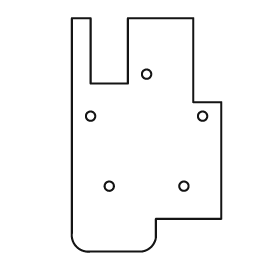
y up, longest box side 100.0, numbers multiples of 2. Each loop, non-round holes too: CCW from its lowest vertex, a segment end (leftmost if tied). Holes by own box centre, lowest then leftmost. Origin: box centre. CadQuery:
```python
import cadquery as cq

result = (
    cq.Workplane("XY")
    .moveTo(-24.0, -50.0)
    .lineTo(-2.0, -50.0)
    .threePointArc((2.0, -48.0), (4.0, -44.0))
    .lineTo(4.0, -36.0)
    .lineTo(32.0, -36.0)
    .lineTo(32.0, 14.0)
    .lineTo(20.0, 14.0)
    .lineTo(20.0, 50.0)
    .lineTo(-8.0, 50.0)
    .lineTo(-8.0, 22.0)
    .lineTo(-24.0, 22.0)
    .lineTo(-24.0, 50.0)
    .lineTo(-32.0, 50.0)
    .lineTo(-32.0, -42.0)
    .threePointArc((-30.0, -48.0), (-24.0, -50.0))
    .close()
    .moveTo(-16.0, -22.0)
    .circle(2.0)
    .moveTo(16.0, -22.0)
    .circle(2.0)
    .moveTo(-24.0, 8.0)
    .circle(2.0)
    .moveTo(24.0, 8.0)
    .circle(2.0)
    .moveTo(0.0, 26.0)
    .circle(2.0)
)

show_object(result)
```